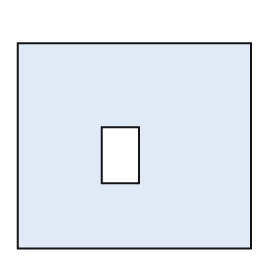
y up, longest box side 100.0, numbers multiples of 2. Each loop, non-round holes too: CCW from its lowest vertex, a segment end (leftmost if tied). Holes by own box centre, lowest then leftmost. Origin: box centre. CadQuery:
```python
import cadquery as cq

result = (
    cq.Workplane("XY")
    .moveTo(-50.0, -44.0)
    .lineTo(50.0, -44.0)
    .lineTo(50.0, 44.0)
    .lineTo(-50.0, 44.0)
    .close()
    .moveTo(-14.0, -16.0)
    .lineTo(2.0, -16.0)
    .lineTo(2.0, 8.0)
    .lineTo(-14.0, 8.0)
    .close()
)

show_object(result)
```